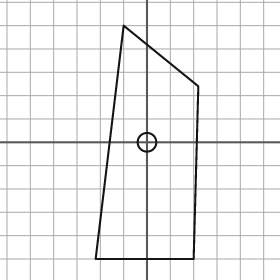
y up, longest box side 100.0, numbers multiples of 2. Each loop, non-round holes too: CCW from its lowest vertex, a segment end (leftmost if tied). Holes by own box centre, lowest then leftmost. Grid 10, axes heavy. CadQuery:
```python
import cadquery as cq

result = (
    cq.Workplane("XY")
    .moveTo(-22.0, -50.0)
    .lineTo(20.0, -50.0)
    .lineTo(22.0, 24.0)
    .lineTo(-10.0, 50.0)
    .close()
    .moveTo(0.0, 0.0)
    .circle(4.0)
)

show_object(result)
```